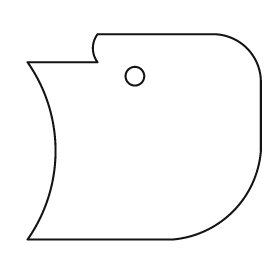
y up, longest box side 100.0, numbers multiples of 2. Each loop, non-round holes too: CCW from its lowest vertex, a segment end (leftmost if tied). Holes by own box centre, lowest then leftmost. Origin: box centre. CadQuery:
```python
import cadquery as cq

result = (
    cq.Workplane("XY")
    .moveTo(-50.0, -44.0)
    .lineTo(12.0, -44.0)
    .threePointArc((38.0, -32.0), (50.0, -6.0))
    .lineTo(50.0, 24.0)
    .threePointArc((44.0, 38.0), (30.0, 44.0))
    .lineTo(-20.0, 44.0)
    .threePointArc((-22.0, 38.0), (-20.0, 32.0))
    .lineTo(-50.0, 32.0)
    .threePointArc((-38.0, -6.0), (-50.0, -44.0))
    .close()
    .moveTo(-4.0, 26.0)
    .circle(4.0)
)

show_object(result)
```